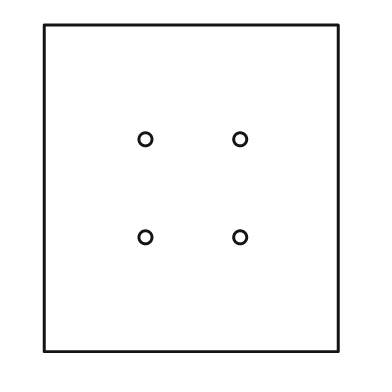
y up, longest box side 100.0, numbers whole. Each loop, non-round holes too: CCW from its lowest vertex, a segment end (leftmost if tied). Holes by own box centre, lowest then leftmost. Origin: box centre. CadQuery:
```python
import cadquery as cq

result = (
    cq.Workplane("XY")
    .moveTo(-45.0, -50.0)
    .lineTo(45.0, -50.0)
    .lineTo(45.0, 50.0)
    .lineTo(-45.0, 50.0)
    .close()
    .moveTo(-14.0, -15.0)
    .circle(2.0)
    .moveTo(15.0, -15.0)
    .circle(2.0)
    .moveTo(-14.0, 15.0)
    .circle(2.0)
    .moveTo(15.0, 15.0)
    .circle(2.0)
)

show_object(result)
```